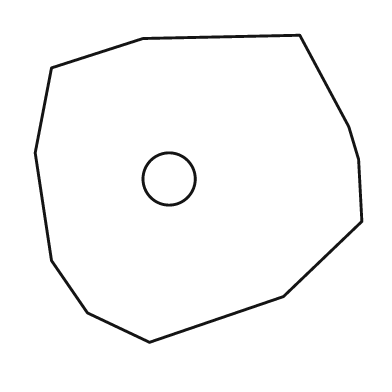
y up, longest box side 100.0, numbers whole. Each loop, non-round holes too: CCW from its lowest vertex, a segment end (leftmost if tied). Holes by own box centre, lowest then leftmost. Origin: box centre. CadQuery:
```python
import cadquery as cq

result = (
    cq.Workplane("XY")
    .moveTo(-15.0, -47.0)
    .lineTo(26.0, -33.0)
    .lineTo(50.0, -10.0)
    .lineTo(49.0, 9.0)
    .lineTo(46.0, 19.0)
    .lineTo(31.0, 47.0)
    .lineTo(-17.0, 46.0)
    .lineTo(-45.0, 37.0)
    .lineTo(-50.0, 11.0)
    .lineTo(-45.0, -22.0)
    .lineTo(-34.0, -38.0)
    .close()
    .moveTo(-9.0, 3.0)
    .circle(8.0)
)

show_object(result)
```